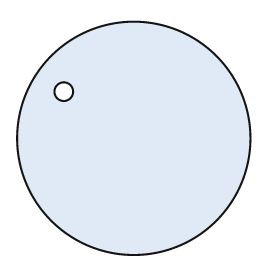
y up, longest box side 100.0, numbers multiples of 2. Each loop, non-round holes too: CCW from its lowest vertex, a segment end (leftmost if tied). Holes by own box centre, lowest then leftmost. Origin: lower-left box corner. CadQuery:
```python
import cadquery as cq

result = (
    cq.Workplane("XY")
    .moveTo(50.0, 50.0)
    .circle(50.0)
    .moveTo(20.0, 70.0)
    .circle(4.0)
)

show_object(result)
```